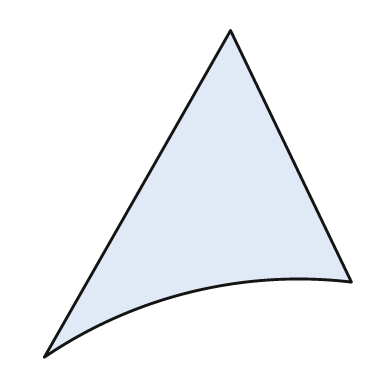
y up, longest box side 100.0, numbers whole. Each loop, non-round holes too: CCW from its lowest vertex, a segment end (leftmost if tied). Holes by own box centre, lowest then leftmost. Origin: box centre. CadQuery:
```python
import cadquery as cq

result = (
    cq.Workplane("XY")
    .moveTo(-47.0, -50.0)
    .threePointArc((-2.0, -30.0), (47.0, -27.0))
    .lineTo(10.0, 50.0)
    .close()
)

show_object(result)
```